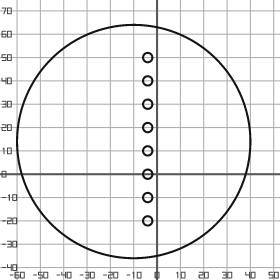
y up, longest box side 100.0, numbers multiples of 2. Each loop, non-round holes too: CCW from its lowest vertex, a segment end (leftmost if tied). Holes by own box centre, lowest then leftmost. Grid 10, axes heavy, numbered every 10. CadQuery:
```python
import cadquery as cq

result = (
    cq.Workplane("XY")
    .moveTo(-10.0, 14.0)
    .circle(50.0)
    .moveTo(-4.0, -20.0)
    .circle(2.0)
    .moveTo(-4.0, -10.0)
    .circle(2.0)
    .moveTo(-4.0, 0.0)
    .circle(2.0)
    .moveTo(-4.0, 10.0)
    .circle(2.0)
    .moveTo(-4.0, 20.0)
    .circle(2.0)
    .moveTo(-4.0, 30.0)
    .circle(2.0)
    .moveTo(-4.0, 40.0)
    .circle(2.0)
    .moveTo(-4.0, 50.0)
    .circle(2.0)
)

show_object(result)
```